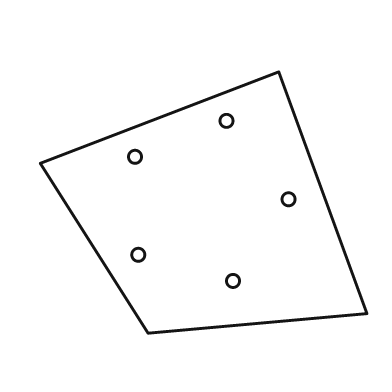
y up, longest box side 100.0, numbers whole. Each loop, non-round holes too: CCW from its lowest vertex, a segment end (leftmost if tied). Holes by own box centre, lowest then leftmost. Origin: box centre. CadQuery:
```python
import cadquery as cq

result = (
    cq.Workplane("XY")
    .moveTo(-17.0, -40.0)
    .lineTo(50.0, -34.0)
    .lineTo(23.0, 40.0)
    .lineTo(-50.0, 12.0)
    .close()
    .moveTo(9.0, -24.0)
    .circle(2.0)
    .moveTo(-20.0, -16.0)
    .circle(2.0)
    .moveTo(26.0, 1.0)
    .circle(2.0)
    .moveTo(-21.0, 14.0)
    .circle(2.0)
    .moveTo(7.0, 25.0)
    .circle(2.0)
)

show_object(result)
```